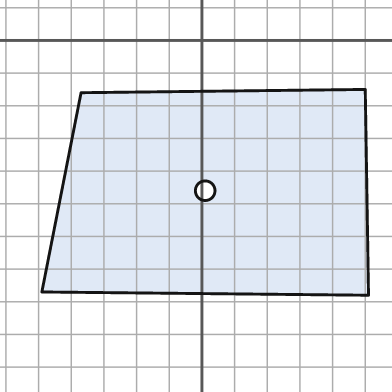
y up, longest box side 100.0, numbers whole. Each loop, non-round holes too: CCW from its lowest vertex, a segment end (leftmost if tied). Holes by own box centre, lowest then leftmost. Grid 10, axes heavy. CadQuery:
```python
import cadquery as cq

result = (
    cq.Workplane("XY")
    .moveTo(51.0, -78.0)
    .lineTo(50.0, -15.0)
    .lineTo(-37.0, -16.0)
    .lineTo(-49.0, -77.0)
    .close()
    .moveTo(1.0, -46.0)
    .circle(3.0)
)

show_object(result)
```